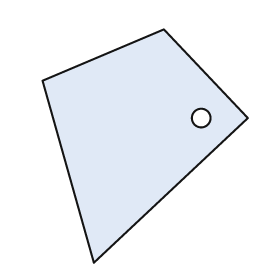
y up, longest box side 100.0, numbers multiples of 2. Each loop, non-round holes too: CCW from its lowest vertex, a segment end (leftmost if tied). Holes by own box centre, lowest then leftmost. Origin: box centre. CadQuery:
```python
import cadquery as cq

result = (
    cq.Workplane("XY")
    .moveTo(-22.0, -50.0)
    .lineTo(44.0, 12.0)
    .lineTo(8.0, 50.0)
    .lineTo(-44.0, 28.0)
    .close()
    .moveTo(24.0, 12.0)
    .circle(4.0)
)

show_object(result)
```